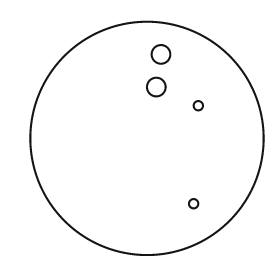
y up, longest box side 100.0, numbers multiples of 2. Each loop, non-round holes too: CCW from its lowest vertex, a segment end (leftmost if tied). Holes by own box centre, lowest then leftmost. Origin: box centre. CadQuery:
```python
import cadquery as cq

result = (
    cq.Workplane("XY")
    .moveTo(0.0, 0.0)
    .circle(50.0)
    .moveTo(20.0, -28.0)
    .circle(2.0)
    .moveTo(22.0, 14.0)
    .circle(2.0)
    .moveTo(4.0, 22.0)
    .circle(4.0)
    .moveTo(6.0, 36.0)
    .circle(4.0)
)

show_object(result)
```